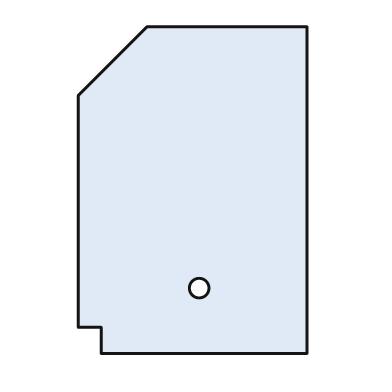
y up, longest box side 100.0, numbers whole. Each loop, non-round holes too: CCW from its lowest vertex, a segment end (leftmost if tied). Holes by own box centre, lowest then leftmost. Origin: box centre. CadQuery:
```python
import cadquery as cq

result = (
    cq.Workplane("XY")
    .moveTo(-28.0, -50.0)
    .lineTo(35.0, -50.0)
    .lineTo(35.0, 50.0)
    .lineTo(-14.0, 50.0)
    .lineTo(-35.0, 29.0)
    .lineTo(-35.0, -42.0)
    .lineTo(-28.0, -42.0)
    .close()
    .moveTo(2.0, -30.0)
    .circle(3.0)
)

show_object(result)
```